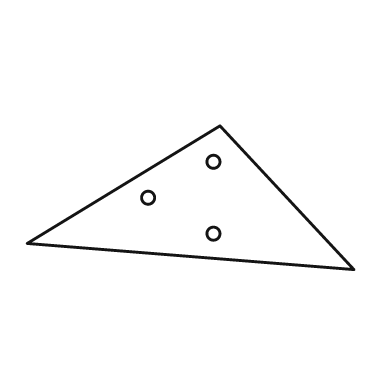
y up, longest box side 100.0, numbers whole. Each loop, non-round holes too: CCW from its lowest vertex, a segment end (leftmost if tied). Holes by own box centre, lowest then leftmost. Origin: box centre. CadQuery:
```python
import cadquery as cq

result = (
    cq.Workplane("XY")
    .moveTo(50.0, -22.0)
    .lineTo(9.0, 22.0)
    .lineTo(-50.0, -14.0)
    .close()
    .moveTo(7.0, -11.0)
    .circle(2.0)
    .moveTo(-13.0, 0.0)
    .circle(2.0)
    .moveTo(7.0, 11.0)
    .circle(2.0)
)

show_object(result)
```